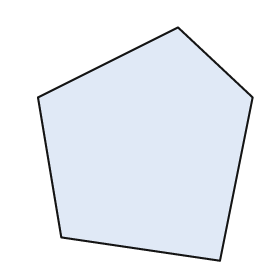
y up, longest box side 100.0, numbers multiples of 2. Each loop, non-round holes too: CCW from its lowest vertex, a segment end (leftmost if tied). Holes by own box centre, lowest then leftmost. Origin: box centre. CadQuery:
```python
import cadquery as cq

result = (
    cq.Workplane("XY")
    .moveTo(32.0, -50.0)
    .lineTo(46.0, 20.0)
    .lineTo(14.0, 50.0)
    .lineTo(-46.0, 20.0)
    .lineTo(-36.0, -40.0)
    .close()
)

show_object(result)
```